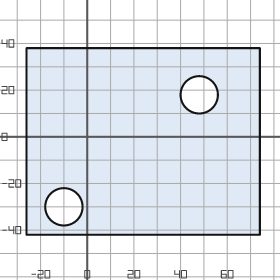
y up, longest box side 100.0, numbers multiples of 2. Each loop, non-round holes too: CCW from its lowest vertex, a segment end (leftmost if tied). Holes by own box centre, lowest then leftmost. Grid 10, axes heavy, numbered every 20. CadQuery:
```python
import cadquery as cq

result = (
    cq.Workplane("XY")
    .moveTo(-26.0, -42.0)
    .lineTo(74.0, -42.0)
    .lineTo(74.0, 38.0)
    .lineTo(-26.0, 38.0)
    .close()
    .moveTo(-10.0, -30.0)
    .circle(8.0)
    .moveTo(48.0, 18.0)
    .circle(8.0)
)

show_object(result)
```